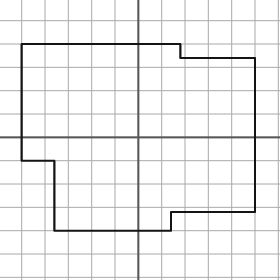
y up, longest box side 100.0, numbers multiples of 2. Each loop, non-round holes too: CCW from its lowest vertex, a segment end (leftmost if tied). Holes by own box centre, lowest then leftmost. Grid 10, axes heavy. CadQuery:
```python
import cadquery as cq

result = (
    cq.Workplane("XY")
    .moveTo(-36.0, -40.0)
    .lineTo(14.0, -40.0)
    .lineTo(14.0, -32.0)
    .lineTo(50.0, -32.0)
    .lineTo(50.0, 34.0)
    .lineTo(18.0, 34.0)
    .lineTo(18.0, 40.0)
    .lineTo(-50.0, 40.0)
    .lineTo(-50.0, -10.0)
    .lineTo(-36.0, -10.0)
    .close()
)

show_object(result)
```